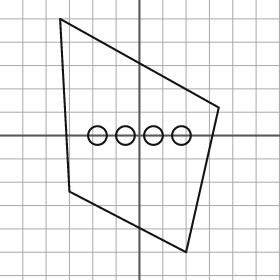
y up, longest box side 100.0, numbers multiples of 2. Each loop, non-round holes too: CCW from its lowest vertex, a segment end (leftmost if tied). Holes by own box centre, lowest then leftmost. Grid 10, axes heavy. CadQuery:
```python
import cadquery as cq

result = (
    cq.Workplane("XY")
    .moveTo(20.0, -50.0)
    .lineTo(34.0, 12.0)
    .lineTo(-34.0, 50.0)
    .lineTo(-30.0, -24.0)
    .close()
    .moveTo(-18.0, 0.0)
    .circle(4.0)
    .moveTo(-6.0, 0.0)
    .circle(4.0)
    .moveTo(6.0, 0.0)
    .circle(4.0)
    .moveTo(18.0, 0.0)
    .circle(4.0)
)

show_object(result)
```